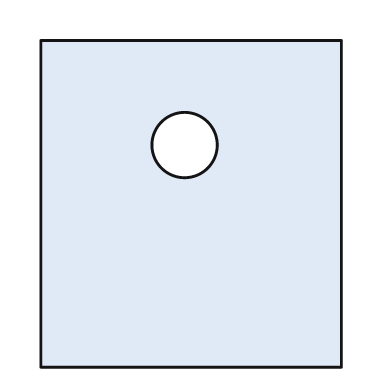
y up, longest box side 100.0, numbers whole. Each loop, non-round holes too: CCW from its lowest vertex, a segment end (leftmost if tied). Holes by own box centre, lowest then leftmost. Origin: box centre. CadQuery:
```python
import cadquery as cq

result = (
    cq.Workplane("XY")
    .moveTo(-46.0, -50.0)
    .lineTo(46.0, -50.0)
    .lineTo(46.0, 50.0)
    .lineTo(-46.0, 50.0)
    .close()
    .moveTo(-2.0, 18.0)
    .circle(10.0)
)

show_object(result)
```